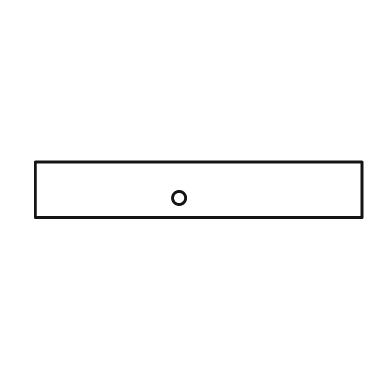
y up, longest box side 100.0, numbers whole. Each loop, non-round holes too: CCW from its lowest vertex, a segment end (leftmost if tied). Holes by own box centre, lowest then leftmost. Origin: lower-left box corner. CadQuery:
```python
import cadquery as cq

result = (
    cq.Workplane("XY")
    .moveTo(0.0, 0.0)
    .lineTo(100.0, 0.0)
    .lineTo(100.0, 17.0)
    .lineTo(0.0, 17.0)
    .close()
    .moveTo(44.0, 6.0)
    .circle(2.0)
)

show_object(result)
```